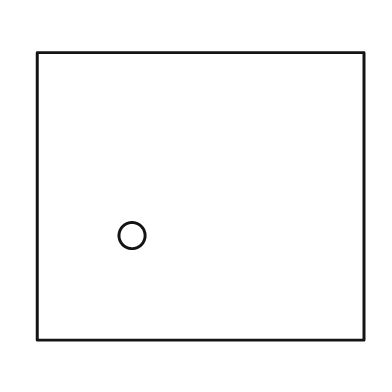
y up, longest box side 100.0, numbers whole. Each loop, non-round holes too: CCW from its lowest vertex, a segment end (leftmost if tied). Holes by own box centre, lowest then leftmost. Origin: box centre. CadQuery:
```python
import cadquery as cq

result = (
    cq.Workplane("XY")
    .moveTo(-50.0, -44.0)
    .lineTo(50.0, -44.0)
    .lineTo(50.0, 44.0)
    .lineTo(-50.0, 44.0)
    .close()
    .moveTo(-21.0, -12.0)
    .circle(4.0)
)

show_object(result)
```